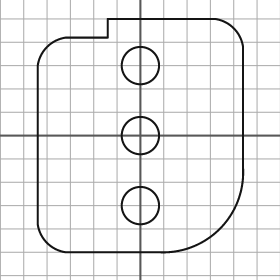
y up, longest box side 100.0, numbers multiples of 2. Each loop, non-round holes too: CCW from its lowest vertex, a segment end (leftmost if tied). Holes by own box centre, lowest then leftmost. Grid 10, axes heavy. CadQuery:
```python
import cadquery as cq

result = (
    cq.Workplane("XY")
    .moveTo(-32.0, -50.0)
    .lineTo(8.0, -50.0)
    .threePointArc((34.0, -40.0), (44.0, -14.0))
    .lineTo(44.0, 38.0)
    .threePointArc((40.0, 46.0), (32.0, 50.0))
    .lineTo(-14.0, 50.0)
    .lineTo(-14.0, 42.0)
    .lineTo(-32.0, 42.0)
    .threePointArc((-40.0, 38.0), (-44.0, 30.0))
    .lineTo(-44.0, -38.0)
    .threePointArc((-40.0, -46.0), (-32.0, -50.0))
    .close()
    .moveTo(0.0, -30.0)
    .circle(8.0)
    .moveTo(0.0, 0.0)
    .circle(8.0)
    .moveTo(0.0, 30.0)
    .circle(8.0)
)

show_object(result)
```